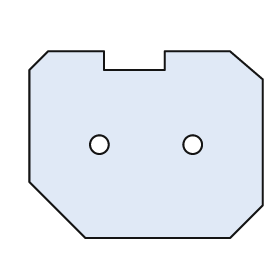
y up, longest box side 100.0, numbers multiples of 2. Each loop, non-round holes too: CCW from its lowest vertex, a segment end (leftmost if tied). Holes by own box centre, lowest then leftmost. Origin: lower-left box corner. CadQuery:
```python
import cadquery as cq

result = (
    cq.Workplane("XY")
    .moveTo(24.0, 0.0)
    .lineTo(86.0, 0.0)
    .lineTo(100.0, 14.0)
    .lineTo(100.0, 68.0)
    .lineTo(86.0, 80.0)
    .lineTo(58.0, 80.0)
    .lineTo(58.0, 72.0)
    .lineTo(32.0, 72.0)
    .lineTo(32.0, 80.0)
    .lineTo(8.0, 80.0)
    .lineTo(0.0, 72.0)
    .lineTo(0.0, 24.0)
    .close()
    .moveTo(30.0, 40.0)
    .circle(4.0)
    .moveTo(70.0, 40.0)
    .circle(4.0)
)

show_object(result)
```